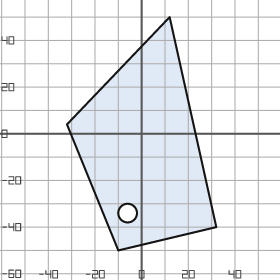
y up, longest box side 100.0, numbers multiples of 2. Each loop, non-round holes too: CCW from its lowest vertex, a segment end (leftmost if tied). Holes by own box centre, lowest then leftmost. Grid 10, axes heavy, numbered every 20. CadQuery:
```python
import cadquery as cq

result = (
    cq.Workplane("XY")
    .moveTo(-10.0, -50.0)
    .lineTo(32.0, -40.0)
    .lineTo(12.0, 50.0)
    .lineTo(-32.0, 4.0)
    .close()
    .moveTo(-6.0, -34.0)
    .circle(4.0)
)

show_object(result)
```